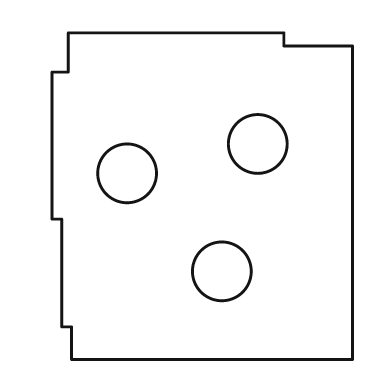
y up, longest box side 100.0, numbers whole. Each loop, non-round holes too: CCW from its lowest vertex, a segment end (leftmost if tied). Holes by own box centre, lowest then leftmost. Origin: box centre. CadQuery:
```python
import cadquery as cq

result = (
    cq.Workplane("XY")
    .moveTo(-40.0, -50.0)
    .lineTo(46.0, -50.0)
    .lineTo(46.0, 46.0)
    .lineTo(25.0, 46.0)
    .lineTo(25.0, 50.0)
    .lineTo(-41.0, 50.0)
    .lineTo(-41.0, 38.0)
    .lineTo(-46.0, 38.0)
    .lineTo(-46.0, -7.0)
    .lineTo(-43.0, -7.0)
    .lineTo(-43.0, -40.0)
    .lineTo(-40.0, -40.0)
    .close()
    .moveTo(6.0, -23.0)
    .circle(9.0)
    .moveTo(-23.0, 7.0)
    .circle(9.0)
    .moveTo(17.0, 16.0)
    .circle(9.0)
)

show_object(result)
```